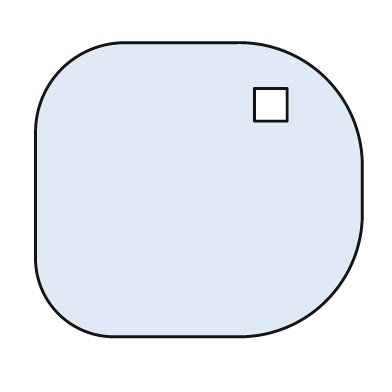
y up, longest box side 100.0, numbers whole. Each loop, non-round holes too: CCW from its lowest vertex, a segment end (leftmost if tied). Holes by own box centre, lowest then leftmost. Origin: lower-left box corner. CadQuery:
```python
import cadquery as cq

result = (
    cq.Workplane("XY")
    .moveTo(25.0, 0.0)
    .lineTo(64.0, 0.0)
    .threePointArc((89.0, 11.0), (100.0, 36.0))
    .lineTo(100.0, 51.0)
    .threePointArc((89.0, 79.0), (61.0, 90.0))
    .lineTo(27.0, 90.0)
    .threePointArc((8.0, 82.0), (0.0, 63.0))
    .lineTo(0.0, 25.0)
    .threePointArc((7.0, 7.0), (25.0, 0.0))
    .close()
    .moveTo(67.0, 66.0)
    .lineTo(77.0, 66.0)
    .lineTo(77.0, 76.0)
    .lineTo(67.0, 76.0)
    .close()
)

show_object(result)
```